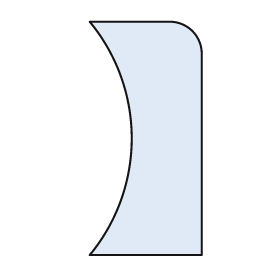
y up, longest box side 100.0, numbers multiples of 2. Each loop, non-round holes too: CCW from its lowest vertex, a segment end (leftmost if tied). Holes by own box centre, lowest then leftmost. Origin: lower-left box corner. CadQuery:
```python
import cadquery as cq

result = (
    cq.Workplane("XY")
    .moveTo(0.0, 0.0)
    .lineTo(48.0, 0.0)
    .lineTo(48.0, 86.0)
    .threePointArc((44.0, 96.0), (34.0, 100.0))
    .lineTo(0.0, 100.0)
    .threePointArc((18.0, 50.0), (0.0, 0.0))
    .close()
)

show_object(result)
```